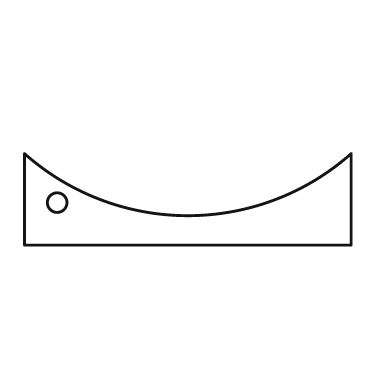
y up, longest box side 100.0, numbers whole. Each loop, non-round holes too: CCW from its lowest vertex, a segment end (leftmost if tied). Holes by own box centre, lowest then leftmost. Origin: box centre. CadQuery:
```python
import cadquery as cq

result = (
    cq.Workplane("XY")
    .moveTo(-50.0, -14.0)
    .lineTo(50.0, -14.0)
    .lineTo(50.0, 14.0)
    .threePointArc((0.0, -5.0), (-50.0, 14.0))
    .close()
    .moveTo(-40.0, -1.0)
    .circle(3.0)
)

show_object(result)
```